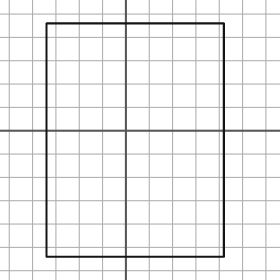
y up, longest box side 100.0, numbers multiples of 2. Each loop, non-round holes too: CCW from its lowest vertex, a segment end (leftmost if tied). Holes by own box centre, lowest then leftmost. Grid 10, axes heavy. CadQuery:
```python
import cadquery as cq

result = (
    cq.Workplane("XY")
    .moveTo(-34.0, -54.0)
    .lineTo(42.0, -54.0)
    .lineTo(42.0, 46.0)
    .lineTo(-34.0, 46.0)
    .close()
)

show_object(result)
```